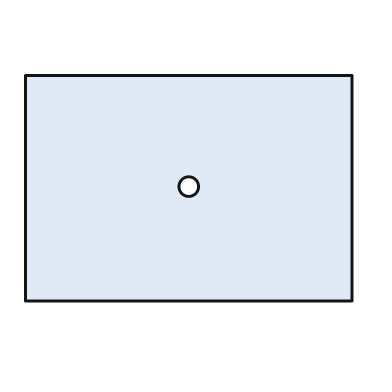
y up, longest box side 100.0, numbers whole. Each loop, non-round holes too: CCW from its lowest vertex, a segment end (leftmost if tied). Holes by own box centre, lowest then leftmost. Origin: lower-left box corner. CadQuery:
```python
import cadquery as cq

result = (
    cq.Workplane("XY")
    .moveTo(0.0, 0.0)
    .lineTo(100.0, 0.0)
    .lineTo(100.0, 69.0)
    .lineTo(0.0, 69.0)
    .close()
    .moveTo(50.0, 35.0)
    .circle(3.0)
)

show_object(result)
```